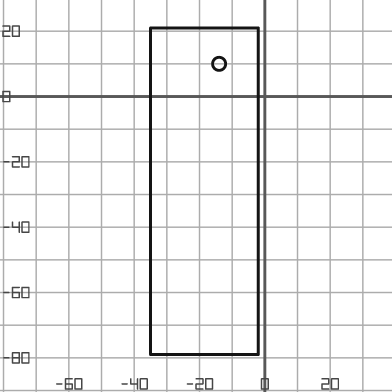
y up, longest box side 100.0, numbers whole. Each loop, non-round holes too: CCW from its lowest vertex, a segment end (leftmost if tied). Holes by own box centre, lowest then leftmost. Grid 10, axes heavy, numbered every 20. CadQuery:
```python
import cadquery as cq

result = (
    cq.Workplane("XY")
    .moveTo(-35.0, -79.0)
    .lineTo(-2.0, -79.0)
    .lineTo(-2.0, 21.0)
    .lineTo(-35.0, 21.0)
    .close()
    .moveTo(-14.0, 10.0)
    .circle(2.0)
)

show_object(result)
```